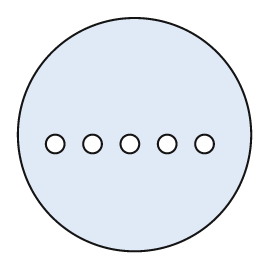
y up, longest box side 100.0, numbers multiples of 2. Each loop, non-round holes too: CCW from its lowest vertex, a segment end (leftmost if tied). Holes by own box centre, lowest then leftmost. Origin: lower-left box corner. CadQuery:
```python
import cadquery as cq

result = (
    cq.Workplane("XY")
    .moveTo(50.0, 50.0)
    .circle(50.0)
    .moveTo(16.0, 46.0)
    .circle(4.0)
    .moveTo(32.0, 46.0)
    .circle(4.0)
    .moveTo(48.0, 46.0)
    .circle(4.0)
    .moveTo(64.0, 46.0)
    .circle(4.0)
    .moveTo(80.0, 46.0)
    .circle(4.0)
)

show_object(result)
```